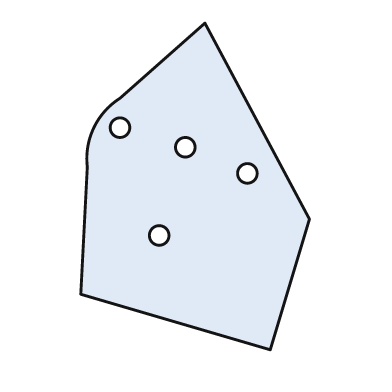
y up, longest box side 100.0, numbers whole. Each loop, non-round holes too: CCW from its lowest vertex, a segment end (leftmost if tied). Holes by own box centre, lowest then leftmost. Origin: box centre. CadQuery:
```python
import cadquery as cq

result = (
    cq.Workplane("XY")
    .moveTo(23.0, -50.0)
    .lineTo(35.0, -10.0)
    .lineTo(3.0, 50.0)
    .lineTo(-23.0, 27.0)
    .threePointArc((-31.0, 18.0), (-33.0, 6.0))
    .lineTo(-35.0, -33.0)
    .close()
    .moveTo(-11.0, -15.0)
    .circle(3.0)
    .moveTo(16.0, 4.0)
    .circle(3.0)
    .moveTo(-3.0, 12.0)
    .circle(3.0)
    .moveTo(-23.0, 18.0)
    .circle(3.0)
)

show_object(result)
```